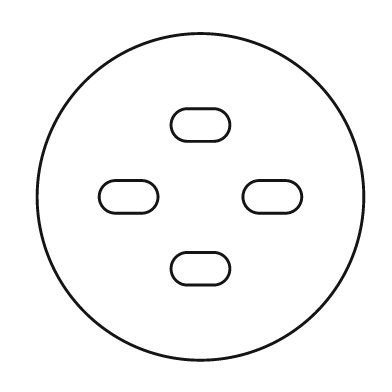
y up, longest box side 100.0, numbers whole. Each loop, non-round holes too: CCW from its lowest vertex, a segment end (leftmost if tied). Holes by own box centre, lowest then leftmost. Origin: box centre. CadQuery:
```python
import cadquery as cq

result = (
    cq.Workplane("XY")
    .moveTo(0.0, 0.0)
    .circle(50.0)
    .moveTo(-4.0, -27.0)
    .lineTo(4.0, -27.0)
    .threePointArc((9.0, -22.0), (4.0, -17.0))
    .lineTo(-4.0, -17.0)
    .threePointArc((-9.0, -22.0), (-4.0, -27.0))
    .close()
    .moveTo(-26.0, -5.0)
    .lineTo(-18.0, -5.0)
    .threePointArc((-13.0, 0.0), (-18.0, 5.0))
    .lineTo(-26.0, 5.0)
    .threePointArc((-31.0, 0.0), (-26.0, -5.0))
    .close()
    .moveTo(18.0, -5.0)
    .lineTo(26.0, -5.0)
    .threePointArc((31.0, 0.0), (26.0, 5.0))
    .lineTo(18.0, 5.0)
    .threePointArc((13.0, 0.0), (18.0, -5.0))
    .close()
    .moveTo(-4.0, 17.0)
    .lineTo(4.0, 17.0)
    .threePointArc((9.0, 22.0), (4.0, 27.0))
    .lineTo(-4.0, 27.0)
    .threePointArc((-9.0, 22.0), (-4.0, 17.0))
    .close()
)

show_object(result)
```